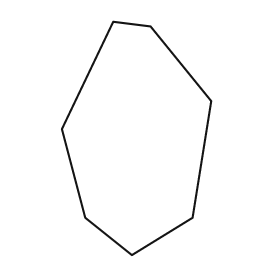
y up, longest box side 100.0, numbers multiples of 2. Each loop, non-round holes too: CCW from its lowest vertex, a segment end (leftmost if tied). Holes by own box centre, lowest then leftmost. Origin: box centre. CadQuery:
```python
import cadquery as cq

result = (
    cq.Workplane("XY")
    .moveTo(-2.0, -50.0)
    .lineTo(24.0, -34.0)
    .lineTo(32.0, 16.0)
    .lineTo(6.0, 48.0)
    .lineTo(-10.0, 50.0)
    .lineTo(-32.0, 4.0)
    .lineTo(-22.0, -34.0)
    .close()
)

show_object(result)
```